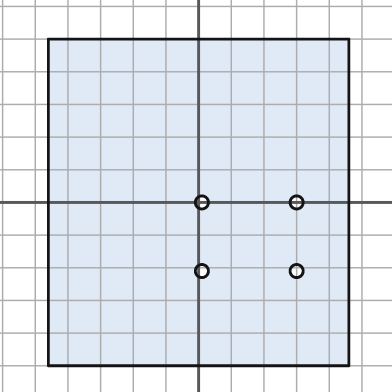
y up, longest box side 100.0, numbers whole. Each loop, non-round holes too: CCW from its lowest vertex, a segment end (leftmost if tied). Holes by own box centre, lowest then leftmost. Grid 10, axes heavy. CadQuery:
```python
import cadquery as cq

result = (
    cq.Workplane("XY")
    .moveTo(-46.0, -50.0)
    .lineTo(46.0, -50.0)
    .lineTo(46.0, 50.0)
    .lineTo(-46.0, 50.0)
    .close()
    .moveTo(1.0, -21.0)
    .circle(2.0)
    .moveTo(30.0, -21.0)
    .circle(2.0)
    .moveTo(1.0, 0.0)
    .circle(2.0)
    .moveTo(30.0, 0.0)
    .circle(2.0)
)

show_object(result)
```